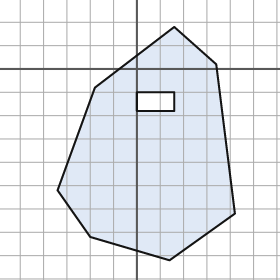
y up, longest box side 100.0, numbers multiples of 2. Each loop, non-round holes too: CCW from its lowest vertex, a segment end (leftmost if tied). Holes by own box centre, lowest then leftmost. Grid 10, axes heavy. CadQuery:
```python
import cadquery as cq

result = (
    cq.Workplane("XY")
    .moveTo(14.0, -82.0)
    .lineTo(42.0, -62.0)
    .lineTo(34.0, 2.0)
    .lineTo(16.0, 18.0)
    .lineTo(-18.0, -8.0)
    .lineTo(-34.0, -52.0)
    .lineTo(-20.0, -72.0)
    .close()
    .moveTo(0.0, -18.0)
    .lineTo(16.0, -18.0)
    .lineTo(16.0, -10.0)
    .lineTo(0.0, -10.0)
    .close()
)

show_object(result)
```